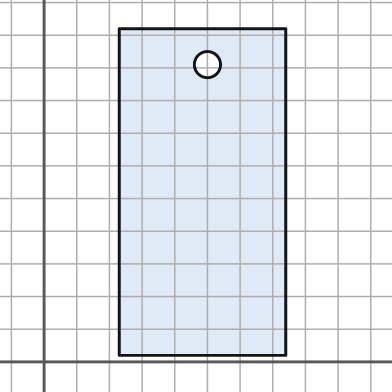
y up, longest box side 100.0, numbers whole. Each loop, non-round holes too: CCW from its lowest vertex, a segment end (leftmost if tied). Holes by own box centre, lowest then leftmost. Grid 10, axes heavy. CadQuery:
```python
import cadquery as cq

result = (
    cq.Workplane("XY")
    .moveTo(23.0, 2.0)
    .lineTo(74.0, 2.0)
    .lineTo(74.0, 102.0)
    .lineTo(23.0, 102.0)
    .close()
    .moveTo(50.0, 91.0)
    .circle(4.0)
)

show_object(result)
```